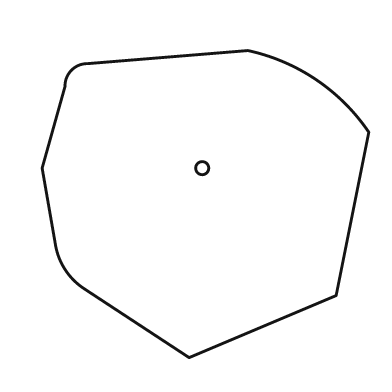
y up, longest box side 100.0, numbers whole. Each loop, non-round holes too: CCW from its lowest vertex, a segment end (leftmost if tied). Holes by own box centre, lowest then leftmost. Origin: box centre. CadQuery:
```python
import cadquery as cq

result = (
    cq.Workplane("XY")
    .moveTo(-5.0, -47.0)
    .lineTo(40.0, -28.0)
    .lineTo(50.0, 22.0)
    .threePointArc((34.0, 38.0), (13.0, 47.0))
    .lineTo(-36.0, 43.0)
    .threePointArc((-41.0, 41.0), (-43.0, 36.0))
    .lineTo(-50.0, 11.0)
    .lineTo(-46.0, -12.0)
    .threePointArc((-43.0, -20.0), (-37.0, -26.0))
    .close()
    .moveTo(-1.0, 11.0)
    .circle(2.0)
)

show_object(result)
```